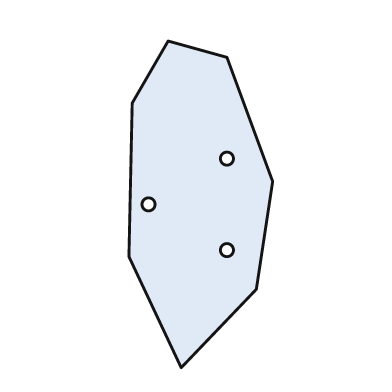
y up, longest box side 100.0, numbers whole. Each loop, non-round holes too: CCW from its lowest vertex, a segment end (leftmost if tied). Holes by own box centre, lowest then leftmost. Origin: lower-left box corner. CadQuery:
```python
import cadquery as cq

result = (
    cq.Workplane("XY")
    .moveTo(16.0, 0.0)
    .lineTo(39.0, 24.0)
    .lineTo(44.0, 57.0)
    .lineTo(30.0, 95.0)
    .lineTo(12.0, 100.0)
    .lineTo(1.0, 81.0)
    .lineTo(0.0, 34.0)
    .close()
    .moveTo(30.0, 36.0)
    .circle(2.0)
    .moveTo(6.0, 50.0)
    .circle(2.0)
    .moveTo(30.0, 64.0)
    .circle(2.0)
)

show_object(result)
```